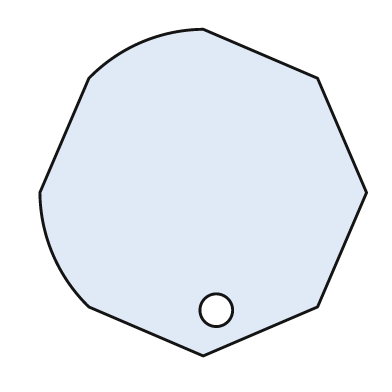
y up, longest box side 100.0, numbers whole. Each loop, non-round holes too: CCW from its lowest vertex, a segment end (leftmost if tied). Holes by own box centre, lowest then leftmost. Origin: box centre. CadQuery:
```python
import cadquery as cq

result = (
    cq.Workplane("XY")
    .moveTo(0.0, -50.0)
    .lineTo(35.0, -35.0)
    .lineTo(50.0, 0.0)
    .lineTo(35.0, 35.0)
    .lineTo(0.0, 50.0)
    .threePointArc((-19.0, 46.0), (-35.0, 35.0))
    .lineTo(-50.0, 0.0)
    .threePointArc((-46.0, -19.0), (-35.0, -35.0))
    .close()
    .moveTo(4.0, -36.0)
    .circle(5.0)
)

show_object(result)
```